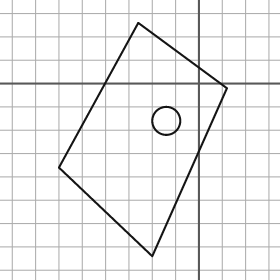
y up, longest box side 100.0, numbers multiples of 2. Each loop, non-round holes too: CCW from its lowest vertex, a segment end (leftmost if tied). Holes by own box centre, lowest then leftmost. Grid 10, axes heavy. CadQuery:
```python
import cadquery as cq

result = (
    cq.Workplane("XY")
    .moveTo(-20.0, -74.0)
    .lineTo(12.0, -2.0)
    .lineTo(-26.0, 26.0)
    .lineTo(-60.0, -36.0)
    .close()
    .moveTo(-14.0, -16.0)
    .circle(6.0)
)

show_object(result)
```